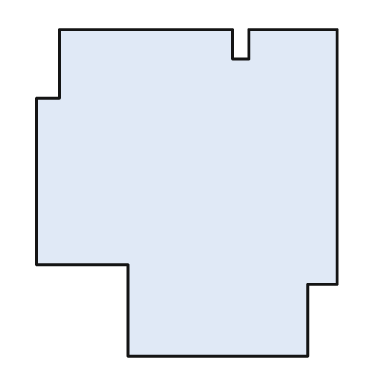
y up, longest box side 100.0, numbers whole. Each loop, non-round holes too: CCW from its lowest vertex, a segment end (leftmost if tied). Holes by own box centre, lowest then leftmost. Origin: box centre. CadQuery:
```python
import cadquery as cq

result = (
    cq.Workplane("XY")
    .moveTo(-18.0, -50.0)
    .lineTo(37.0, -50.0)
    .lineTo(37.0, -28.0)
    .lineTo(46.0, -28.0)
    .lineTo(46.0, 50.0)
    .lineTo(19.0, 50.0)
    .lineTo(19.0, 41.0)
    .lineTo(14.0, 41.0)
    .lineTo(14.0, 50.0)
    .lineTo(-39.0, 50.0)
    .lineTo(-39.0, 29.0)
    .lineTo(-46.0, 29.0)
    .lineTo(-46.0, -22.0)
    .lineTo(-18.0, -22.0)
    .close()
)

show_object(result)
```